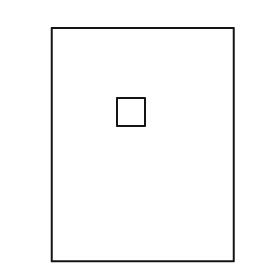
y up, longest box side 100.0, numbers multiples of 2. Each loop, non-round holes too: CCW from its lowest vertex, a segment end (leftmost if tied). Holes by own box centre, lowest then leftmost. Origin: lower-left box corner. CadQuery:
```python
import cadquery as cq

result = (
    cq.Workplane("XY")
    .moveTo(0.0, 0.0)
    .lineTo(78.0, 0.0)
    .lineTo(78.0, 100.0)
    .lineTo(0.0, 100.0)
    .close()
    .moveTo(28.0, 58.0)
    .lineTo(40.0, 58.0)
    .lineTo(40.0, 70.0)
    .lineTo(28.0, 70.0)
    .close()
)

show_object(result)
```